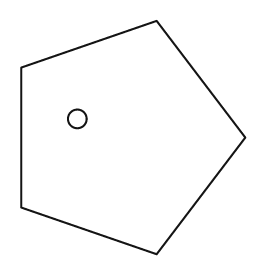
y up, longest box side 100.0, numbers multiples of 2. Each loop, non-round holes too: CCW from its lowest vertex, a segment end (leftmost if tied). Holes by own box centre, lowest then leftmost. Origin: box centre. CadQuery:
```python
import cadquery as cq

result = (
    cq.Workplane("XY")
    .moveTo(10.0, -50.0)
    .lineTo(48.0, 0.0)
    .lineTo(10.0, 50.0)
    .lineTo(-48.0, 30.0)
    .lineTo(-48.0, -30.0)
    .close()
    .moveTo(-24.0, 8.0)
    .circle(4.0)
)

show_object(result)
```